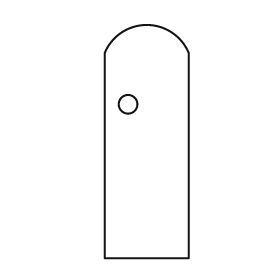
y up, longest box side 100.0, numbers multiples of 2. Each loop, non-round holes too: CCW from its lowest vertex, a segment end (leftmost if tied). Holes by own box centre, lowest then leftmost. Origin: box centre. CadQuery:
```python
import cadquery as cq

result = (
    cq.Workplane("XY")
    .moveTo(-18.0, -50.0)
    .lineTo(18.0, -50.0)
    .lineTo(18.0, 38.0)
    .threePointArc((0.0, 50.0), (-18.0, 38.0))
    .close()
    .moveTo(-8.0, 16.0)
    .circle(4.0)
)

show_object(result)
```